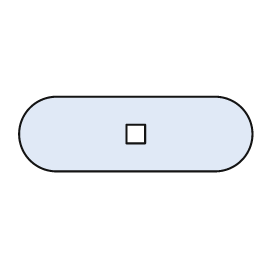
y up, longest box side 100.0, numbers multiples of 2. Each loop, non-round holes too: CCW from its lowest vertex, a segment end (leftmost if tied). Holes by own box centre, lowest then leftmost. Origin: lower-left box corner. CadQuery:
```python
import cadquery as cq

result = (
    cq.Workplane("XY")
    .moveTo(16.0, 0.0)
    .lineTo(84.0, 0.0)
    .threePointArc((100.0, 16.0), (84.0, 32.0))
    .lineTo(16.0, 32.0)
    .threePointArc((0.0, 16.0), (16.0, 0.0))
    .close()
    .moveTo(46.0, 12.0)
    .lineTo(54.0, 12.0)
    .lineTo(54.0, 20.0)
    .lineTo(46.0, 20.0)
    .close()
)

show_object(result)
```